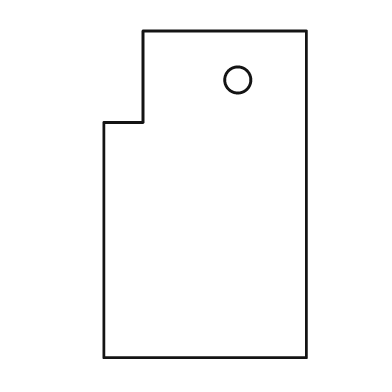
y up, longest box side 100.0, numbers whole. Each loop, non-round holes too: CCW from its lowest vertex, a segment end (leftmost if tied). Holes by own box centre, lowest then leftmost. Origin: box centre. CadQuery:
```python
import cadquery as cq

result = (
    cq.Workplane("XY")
    .moveTo(-31.0, -50.0)
    .lineTo(31.0, -50.0)
    .lineTo(31.0, 50.0)
    .lineTo(-19.0, 50.0)
    .lineTo(-19.0, 22.0)
    .lineTo(-31.0, 22.0)
    .close()
    .moveTo(10.0, 35.0)
    .circle(4.0)
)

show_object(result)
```